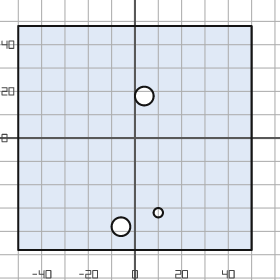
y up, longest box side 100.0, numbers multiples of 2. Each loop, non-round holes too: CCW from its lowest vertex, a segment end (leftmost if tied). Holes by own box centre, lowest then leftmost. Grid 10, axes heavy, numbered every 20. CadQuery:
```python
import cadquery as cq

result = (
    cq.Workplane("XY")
    .moveTo(-50.0, -48.0)
    .lineTo(50.0, -48.0)
    .lineTo(50.0, 48.0)
    .lineTo(-50.0, 48.0)
    .close()
    .moveTo(-6.0, -38.0)
    .circle(4.0)
    .moveTo(10.0, -32.0)
    .circle(2.0)
    .moveTo(4.0, 18.0)
    .circle(4.0)
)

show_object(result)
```